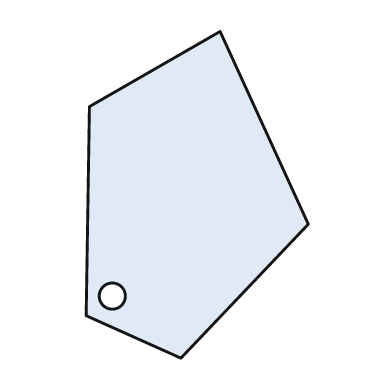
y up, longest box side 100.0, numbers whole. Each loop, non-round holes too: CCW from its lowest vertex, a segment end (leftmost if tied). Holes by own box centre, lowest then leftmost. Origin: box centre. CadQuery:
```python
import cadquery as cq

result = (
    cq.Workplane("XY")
    .moveTo(-5.0, -50.0)
    .lineTo(34.0, -9.0)
    .lineTo(7.0, 50.0)
    .lineTo(-33.0, 27.0)
    .lineTo(-34.0, -37.0)
    .close()
    .moveTo(-26.0, -31.0)
    .circle(4.0)
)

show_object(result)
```